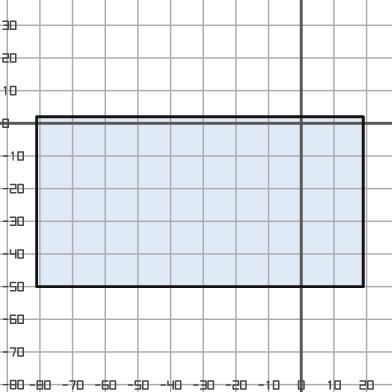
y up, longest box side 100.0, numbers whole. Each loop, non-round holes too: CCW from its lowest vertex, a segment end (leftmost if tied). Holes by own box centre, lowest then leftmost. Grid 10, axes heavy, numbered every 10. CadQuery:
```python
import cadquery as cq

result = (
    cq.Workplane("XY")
    .moveTo(-81.0, -50.0)
    .lineTo(19.0, -50.0)
    .lineTo(19.0, 2.0)
    .lineTo(-81.0, 2.0)
    .close()
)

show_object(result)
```